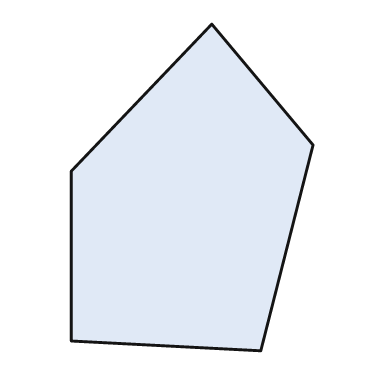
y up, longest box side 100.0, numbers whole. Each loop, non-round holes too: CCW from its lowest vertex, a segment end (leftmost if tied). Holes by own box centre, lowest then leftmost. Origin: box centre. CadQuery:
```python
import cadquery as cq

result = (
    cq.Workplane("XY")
    .moveTo(21.0, -50.0)
    .lineTo(37.0, 13.0)
    .lineTo(6.0, 50.0)
    .lineTo(-37.0, 5.0)
    .lineTo(-37.0, -47.0)
    .close()
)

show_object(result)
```